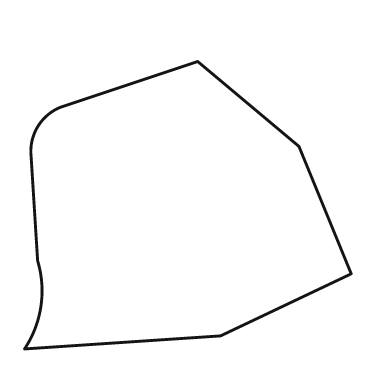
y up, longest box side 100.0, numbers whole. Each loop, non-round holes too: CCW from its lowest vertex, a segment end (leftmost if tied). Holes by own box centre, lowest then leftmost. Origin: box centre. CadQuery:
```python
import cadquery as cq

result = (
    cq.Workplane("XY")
    .moveTo(-50.0, -44.0)
    .lineTo(10.0, -40.0)
    .lineTo(50.0, -21.0)
    .lineTo(34.0, 18.0)
    .lineTo(3.0, 44.0)
    .lineTo(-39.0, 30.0)
    .threePointArc((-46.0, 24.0), (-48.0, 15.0))
    .lineTo(-46.0, -17.0)
    .threePointArc((-45.0, -31.0), (-50.0, -44.0))
    .close()
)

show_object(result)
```